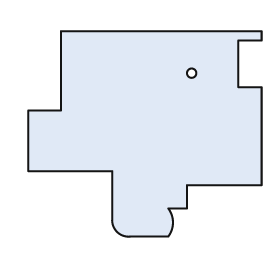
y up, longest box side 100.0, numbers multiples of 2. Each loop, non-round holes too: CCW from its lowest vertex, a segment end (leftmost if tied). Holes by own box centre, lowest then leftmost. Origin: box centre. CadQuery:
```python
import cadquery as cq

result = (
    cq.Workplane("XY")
    .moveTo(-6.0, -44.0)
    .lineTo(10.0, -44.0)
    .threePointArc((12.0, -38.0), (10.0, -32.0))
    .lineTo(18.0, -32.0)
    .lineTo(18.0, -22.0)
    .lineTo(50.0, -22.0)
    .lineTo(50.0, 20.0)
    .lineTo(40.0, 20.0)
    .lineTo(40.0, 40.0)
    .lineTo(50.0, 40.0)
    .lineTo(50.0, 44.0)
    .lineTo(-36.0, 44.0)
    .lineTo(-36.0, 10.0)
    .lineTo(-50.0, 10.0)
    .lineTo(-50.0, -16.0)
    .lineTo(-14.0, -16.0)
    .lineTo(-14.0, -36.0)
    .threePointArc((-12.0, -42.0), (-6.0, -44.0))
    .close()
    .moveTo(20.0, 26.0)
    .circle(2.0)
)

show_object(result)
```